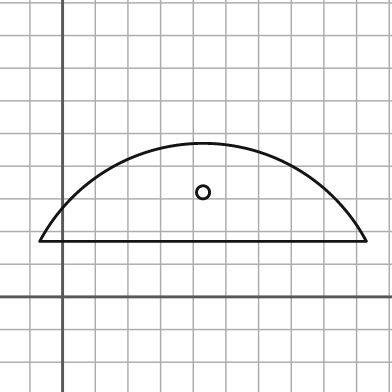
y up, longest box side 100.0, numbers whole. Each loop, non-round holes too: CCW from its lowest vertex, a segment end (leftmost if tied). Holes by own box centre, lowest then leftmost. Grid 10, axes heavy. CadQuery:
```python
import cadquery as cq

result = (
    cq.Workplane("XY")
    .moveTo(-7.0, 17.0)
    .lineTo(93.0, 17.0)
    .threePointArc((43.0, 47.0), (-7.0, 17.0))
    .close()
    .moveTo(43.0, 32.0)
    .circle(2.0)
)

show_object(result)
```